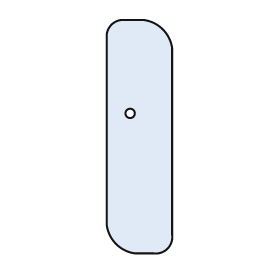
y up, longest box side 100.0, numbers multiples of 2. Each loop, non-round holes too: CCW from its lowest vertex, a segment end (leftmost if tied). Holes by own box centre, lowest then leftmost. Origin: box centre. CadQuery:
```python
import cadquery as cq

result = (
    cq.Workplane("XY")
    .moveTo(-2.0, -50.0)
    .lineTo(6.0, -50.0)
    .threePointArc((12.0, -48.0), (14.0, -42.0))
    .lineTo(14.0, 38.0)
    .threePointArc((10.0, 46.0), (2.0, 50.0))
    .lineTo(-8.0, 50.0)
    .threePointArc((-12.0, 48.0), (-14.0, 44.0))
    .lineTo(-14.0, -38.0)
    .threePointArc((-10.0, -46.0), (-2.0, -50.0))
    .close()
    .moveTo(-4.0, 10.0)
    .circle(2.0)
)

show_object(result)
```